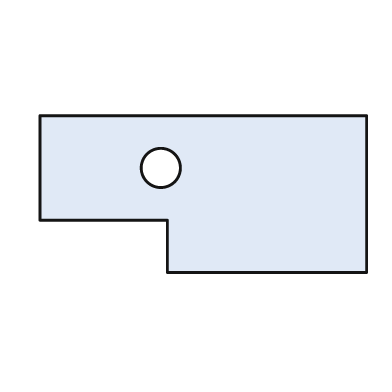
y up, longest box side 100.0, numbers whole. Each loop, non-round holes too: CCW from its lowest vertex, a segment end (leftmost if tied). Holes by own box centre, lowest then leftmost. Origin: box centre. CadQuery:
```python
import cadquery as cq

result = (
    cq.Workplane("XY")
    .moveTo(-11.0, -24.0)
    .lineTo(50.0, -24.0)
    .lineTo(50.0, 24.0)
    .lineTo(-50.0, 24.0)
    .lineTo(-50.0, -8.0)
    .lineTo(-11.0, -8.0)
    .close()
    .moveTo(-13.0, 8.0)
    .circle(6.0)
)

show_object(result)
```